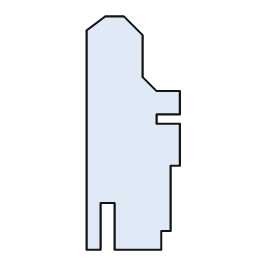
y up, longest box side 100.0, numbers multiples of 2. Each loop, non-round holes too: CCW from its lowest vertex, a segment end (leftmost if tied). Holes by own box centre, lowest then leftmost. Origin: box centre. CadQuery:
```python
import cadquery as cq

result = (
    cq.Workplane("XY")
    .moveTo(-20.0, -50.0)
    .lineTo(-14.0, -50.0)
    .lineTo(-14.0, -30.0)
    .lineTo(-8.0, -30.0)
    .lineTo(-8.0, -50.0)
    .lineTo(12.0, -50.0)
    .lineTo(12.0, -42.0)
    .lineTo(16.0, -42.0)
    .lineTo(16.0, -14.0)
    .lineTo(20.0, -14.0)
    .lineTo(20.0, 4.0)
    .lineTo(10.0, 4.0)
    .lineTo(10.0, 8.0)
    .lineTo(20.0, 8.0)
    .lineTo(20.0, 18.0)
    .lineTo(10.0, 18.0)
    .lineTo(4.0, 24.0)
    .lineTo(4.0, 42.0)
    .lineTo(-4.0, 50.0)
    .lineTo(-12.0, 50.0)
    .lineTo(-20.0, 44.0)
    .close()
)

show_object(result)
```